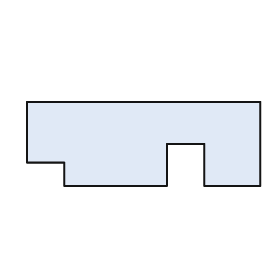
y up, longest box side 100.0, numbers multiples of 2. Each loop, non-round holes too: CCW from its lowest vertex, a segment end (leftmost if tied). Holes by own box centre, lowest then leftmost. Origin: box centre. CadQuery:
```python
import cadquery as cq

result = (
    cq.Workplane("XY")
    .moveTo(-34.0, -18.0)
    .lineTo(10.0, -18.0)
    .lineTo(10.0, 0.0)
    .lineTo(26.0, 0.0)
    .lineTo(26.0, -18.0)
    .lineTo(50.0, -18.0)
    .lineTo(50.0, 18.0)
    .lineTo(-50.0, 18.0)
    .lineTo(-50.0, -8.0)
    .lineTo(-34.0, -8.0)
    .close()
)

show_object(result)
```